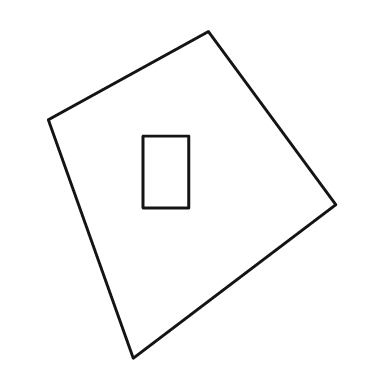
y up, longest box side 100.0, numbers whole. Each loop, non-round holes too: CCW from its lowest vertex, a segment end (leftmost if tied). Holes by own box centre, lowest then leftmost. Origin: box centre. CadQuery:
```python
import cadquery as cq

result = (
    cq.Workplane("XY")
    .moveTo(-18.0, -50.0)
    .lineTo(44.0, -3.0)
    .lineTo(5.0, 50.0)
    .lineTo(-44.0, 23.0)
    .close()
    .moveTo(-15.0, -4.0)
    .lineTo(-1.0, -4.0)
    .lineTo(-1.0, 18.0)
    .lineTo(-15.0, 18.0)
    .close()
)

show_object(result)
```